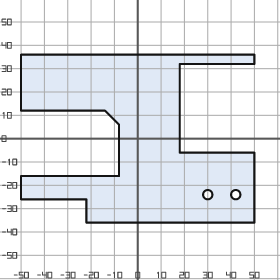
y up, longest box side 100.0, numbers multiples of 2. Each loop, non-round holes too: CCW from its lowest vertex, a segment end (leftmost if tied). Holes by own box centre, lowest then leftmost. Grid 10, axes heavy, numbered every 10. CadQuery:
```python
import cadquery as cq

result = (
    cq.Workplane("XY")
    .moveTo(-22.0, -36.0)
    .lineTo(50.0, -36.0)
    .lineTo(50.0, -6.0)
    .lineTo(18.0, -6.0)
    .lineTo(18.0, 32.0)
    .lineTo(50.0, 32.0)
    .lineTo(50.0, 36.0)
    .lineTo(-50.0, 36.0)
    .lineTo(-50.0, 12.0)
    .lineTo(-14.0, 12.0)
    .lineTo(-8.0, 6.0)
    .lineTo(-8.0, -16.0)
    .lineTo(-50.0, -16.0)
    .lineTo(-50.0, -26.0)
    .lineTo(-22.0, -26.0)
    .close()
    .moveTo(30.0, -24.0)
    .circle(2.0)
    .moveTo(42.0, -24.0)
    .circle(2.0)
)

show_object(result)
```